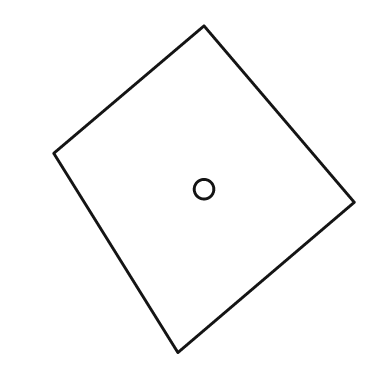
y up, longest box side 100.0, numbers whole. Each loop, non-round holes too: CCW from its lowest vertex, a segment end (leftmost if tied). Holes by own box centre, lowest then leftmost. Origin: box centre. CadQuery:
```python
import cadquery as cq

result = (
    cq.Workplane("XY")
    .moveTo(-8.0, -50.0)
    .lineTo(46.0, -4.0)
    .lineTo(0.0, 50.0)
    .lineTo(-46.0, 11.0)
    .close()
    .moveTo(0.0, 0.0)
    .circle(3.0)
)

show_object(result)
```